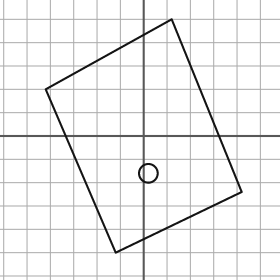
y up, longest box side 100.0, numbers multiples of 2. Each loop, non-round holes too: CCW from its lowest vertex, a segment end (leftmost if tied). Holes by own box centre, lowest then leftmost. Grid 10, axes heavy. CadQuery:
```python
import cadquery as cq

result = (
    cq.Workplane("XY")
    .moveTo(-12.0, -50.0)
    .lineTo(42.0, -24.0)
    .lineTo(12.0, 50.0)
    .lineTo(-42.0, 20.0)
    .close()
    .moveTo(2.0, -16.0)
    .circle(4.0)
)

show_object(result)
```